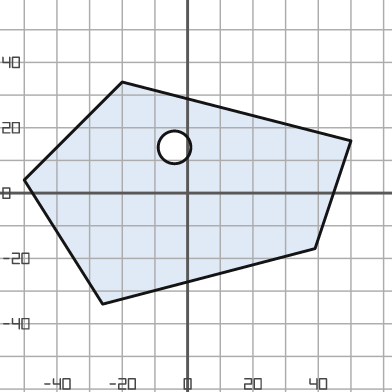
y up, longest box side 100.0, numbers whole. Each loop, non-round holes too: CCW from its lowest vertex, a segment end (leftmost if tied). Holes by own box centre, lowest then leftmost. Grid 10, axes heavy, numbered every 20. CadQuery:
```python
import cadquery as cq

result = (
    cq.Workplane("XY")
    .moveTo(-26.0, -34.0)
    .lineTo(39.0, -17.0)
    .lineTo(50.0, 16.0)
    .lineTo(-20.0, 34.0)
    .lineTo(-50.0, 4.0)
    .close()
    .moveTo(-4.0, 14.0)
    .circle(5.0)
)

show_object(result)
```